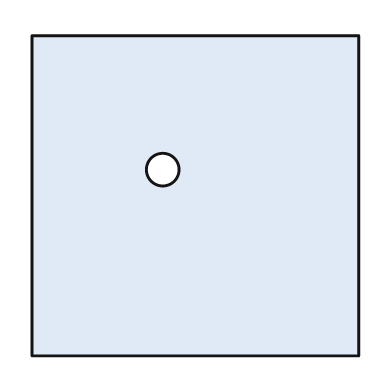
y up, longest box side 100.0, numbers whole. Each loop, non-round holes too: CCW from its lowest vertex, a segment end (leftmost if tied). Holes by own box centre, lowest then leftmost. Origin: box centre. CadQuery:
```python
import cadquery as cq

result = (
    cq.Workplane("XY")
    .moveTo(-50.0, -49.0)
    .lineTo(50.0, -49.0)
    .lineTo(50.0, 49.0)
    .lineTo(-50.0, 49.0)
    .close()
    .moveTo(-10.0, 8.0)
    .circle(5.0)
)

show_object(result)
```